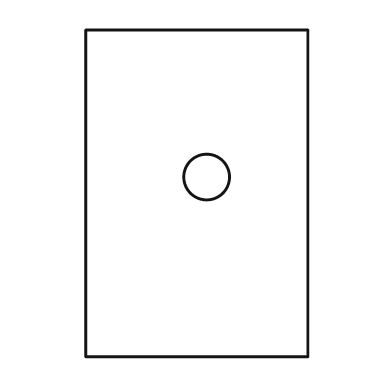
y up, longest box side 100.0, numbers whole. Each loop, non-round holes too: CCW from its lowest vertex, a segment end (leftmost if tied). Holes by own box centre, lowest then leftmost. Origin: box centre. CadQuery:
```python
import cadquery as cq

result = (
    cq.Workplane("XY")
    .moveTo(-34.0, -50.0)
    .lineTo(34.0, -50.0)
    .lineTo(34.0, 50.0)
    .lineTo(-34.0, 50.0)
    .close()
    .moveTo(3.0, 5.0)
    .circle(7.0)
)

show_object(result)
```